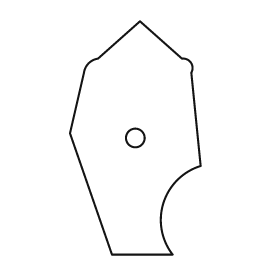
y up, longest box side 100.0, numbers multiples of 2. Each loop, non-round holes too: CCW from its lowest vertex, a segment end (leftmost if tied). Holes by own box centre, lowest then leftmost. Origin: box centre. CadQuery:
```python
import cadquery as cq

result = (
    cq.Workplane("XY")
    .moveTo(-10.0, -50.0)
    .lineTo(16.0, -50.0)
    .threePointArc((12.0, -28.0), (28.0, -12.0))
    .lineTo(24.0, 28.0)
    .threePointArc((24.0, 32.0), (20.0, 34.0))
    .lineTo(2.0, 50.0)
    .lineTo(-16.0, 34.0)
    .threePointArc((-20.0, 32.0), (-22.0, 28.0))
    .lineTo(-28.0, 2.0)
    .close()
    .moveTo(0.0, 0.0)
    .circle(4.0)
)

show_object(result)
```